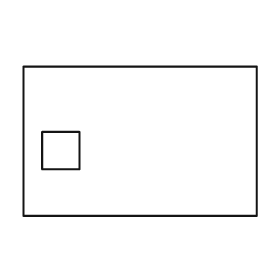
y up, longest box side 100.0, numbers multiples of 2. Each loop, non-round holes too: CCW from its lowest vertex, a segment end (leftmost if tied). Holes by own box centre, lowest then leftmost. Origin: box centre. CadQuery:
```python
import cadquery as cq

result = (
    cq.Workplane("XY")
    .moveTo(-50.0, -32.0)
    .lineTo(50.0, -32.0)
    .lineTo(50.0, 32.0)
    .lineTo(-50.0, 32.0)
    .close()
    .moveTo(-42.0, -12.0)
    .lineTo(-26.0, -12.0)
    .lineTo(-26.0, 4.0)
    .lineTo(-42.0, 4.0)
    .close()
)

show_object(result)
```